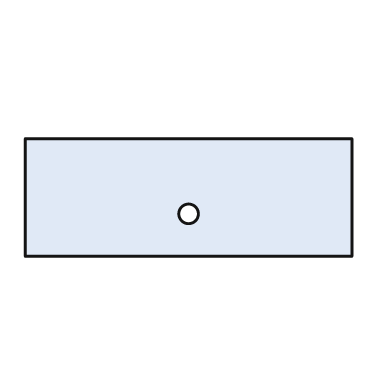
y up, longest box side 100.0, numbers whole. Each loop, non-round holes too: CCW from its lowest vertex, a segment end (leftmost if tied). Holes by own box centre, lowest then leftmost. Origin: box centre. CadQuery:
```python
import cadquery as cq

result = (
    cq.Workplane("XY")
    .moveTo(-50.0, -18.0)
    .lineTo(50.0, -18.0)
    .lineTo(50.0, 18.0)
    .lineTo(-50.0, 18.0)
    .close()
    .moveTo(0.0, -5.0)
    .circle(3.0)
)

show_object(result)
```